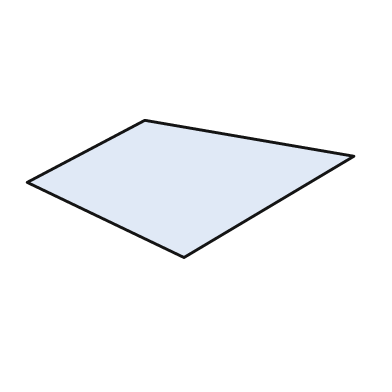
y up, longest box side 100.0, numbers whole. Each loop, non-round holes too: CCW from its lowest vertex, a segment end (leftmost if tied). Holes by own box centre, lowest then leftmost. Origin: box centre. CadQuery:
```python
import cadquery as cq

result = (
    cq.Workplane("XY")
    .moveTo(-2.0, -21.0)
    .lineTo(50.0, 10.0)
    .lineTo(-14.0, 21.0)
    .lineTo(-50.0, 2.0)
    .close()
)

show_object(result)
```